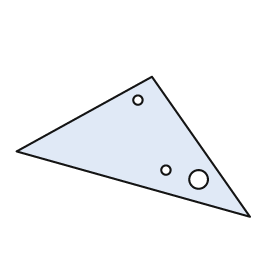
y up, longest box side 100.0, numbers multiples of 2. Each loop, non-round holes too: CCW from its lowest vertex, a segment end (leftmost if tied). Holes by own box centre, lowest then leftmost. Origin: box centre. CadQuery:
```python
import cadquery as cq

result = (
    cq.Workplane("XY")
    .moveTo(50.0, -30.0)
    .lineTo(8.0, 30.0)
    .lineTo(-50.0, -2.0)
    .close()
    .moveTo(28.0, -14.0)
    .circle(4.0)
    .moveTo(14.0, -10.0)
    .circle(2.0)
    .moveTo(2.0, 20.0)
    .circle(2.0)
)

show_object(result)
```